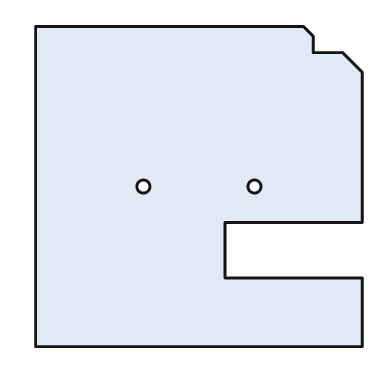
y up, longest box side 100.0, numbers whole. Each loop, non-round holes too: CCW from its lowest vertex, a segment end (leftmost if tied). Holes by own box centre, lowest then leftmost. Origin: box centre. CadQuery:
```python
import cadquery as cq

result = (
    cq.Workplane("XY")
    .moveTo(-50.0, -49.0)
    .lineTo(50.0, -49.0)
    .lineTo(50.0, -28.0)
    .lineTo(8.0, -28.0)
    .lineTo(8.0, -11.0)
    .lineTo(50.0, -11.0)
    .lineTo(50.0, 35.0)
    .lineTo(44.0, 41.0)
    .lineTo(35.0, 41.0)
    .lineTo(35.0, 46.0)
    .lineTo(32.0, 49.0)
    .lineTo(-50.0, 49.0)
    .close()
    .moveTo(-17.0, 0.0)
    .circle(2.0)
    .moveTo(17.0, 0.0)
    .circle(2.0)
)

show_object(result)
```